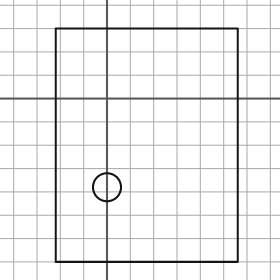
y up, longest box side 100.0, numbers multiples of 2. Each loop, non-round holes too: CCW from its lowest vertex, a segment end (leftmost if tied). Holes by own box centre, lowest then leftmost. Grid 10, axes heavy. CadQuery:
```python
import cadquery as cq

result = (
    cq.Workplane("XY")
    .moveTo(-22.0, -70.0)
    .lineTo(56.0, -70.0)
    .lineTo(56.0, 30.0)
    .lineTo(-22.0, 30.0)
    .close()
    .moveTo(0.0, -38.0)
    .circle(6.0)
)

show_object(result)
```